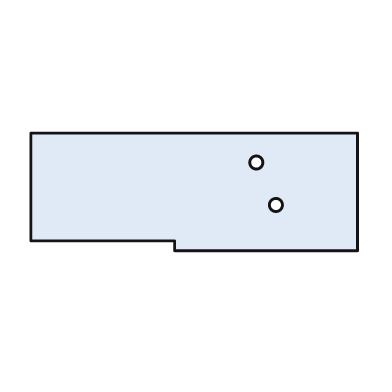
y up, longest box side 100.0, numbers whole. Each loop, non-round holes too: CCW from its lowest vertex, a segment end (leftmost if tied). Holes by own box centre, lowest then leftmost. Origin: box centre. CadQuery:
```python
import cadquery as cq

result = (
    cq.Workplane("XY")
    .moveTo(-6.0, -18.0)
    .lineTo(50.0, -18.0)
    .lineTo(50.0, 18.0)
    .lineTo(-50.0, 18.0)
    .lineTo(-50.0, -15.0)
    .lineTo(-6.0, -15.0)
    .close()
    .moveTo(25.0, -4.0)
    .circle(2.0)
    .moveTo(19.0, 9.0)
    .circle(2.0)
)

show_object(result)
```